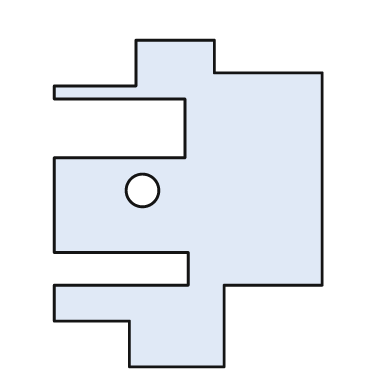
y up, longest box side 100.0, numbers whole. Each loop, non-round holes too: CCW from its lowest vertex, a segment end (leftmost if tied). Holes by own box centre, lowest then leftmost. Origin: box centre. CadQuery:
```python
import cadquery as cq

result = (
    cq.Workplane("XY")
    .moveTo(-18.0, -50.0)
    .lineTo(11.0, -50.0)
    .lineTo(11.0, -25.0)
    .lineTo(41.0, -25.0)
    .lineTo(41.0, 40.0)
    .lineTo(8.0, 40.0)
    .lineTo(8.0, 50.0)
    .lineTo(-16.0, 50.0)
    .lineTo(-16.0, 36.0)
    .lineTo(-41.0, 36.0)
    .lineTo(-41.0, 32.0)
    .lineTo(-1.0, 32.0)
    .lineTo(-1.0, 14.0)
    .lineTo(-41.0, 14.0)
    .lineTo(-41.0, -15.0)
    .lineTo(0.0, -15.0)
    .lineTo(0.0, -25.0)
    .lineTo(-41.0, -25.0)
    .lineTo(-41.0, -36.0)
    .lineTo(-18.0, -36.0)
    .close()
    .moveTo(-14.0, 4.0)
    .circle(5.0)
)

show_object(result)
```